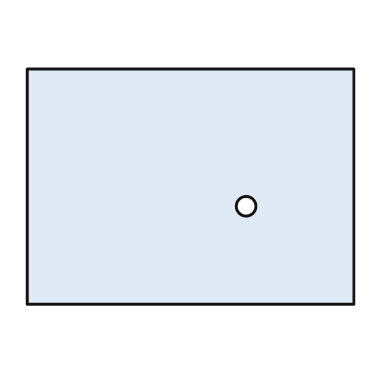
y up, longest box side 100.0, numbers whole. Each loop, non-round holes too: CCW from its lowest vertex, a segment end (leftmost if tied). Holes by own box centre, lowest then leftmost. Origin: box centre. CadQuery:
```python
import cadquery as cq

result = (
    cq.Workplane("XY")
    .moveTo(-50.0, -36.0)
    .lineTo(50.0, -36.0)
    .lineTo(50.0, 36.0)
    .lineTo(-50.0, 36.0)
    .close()
    .moveTo(17.0, -6.0)
    .circle(3.0)
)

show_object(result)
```